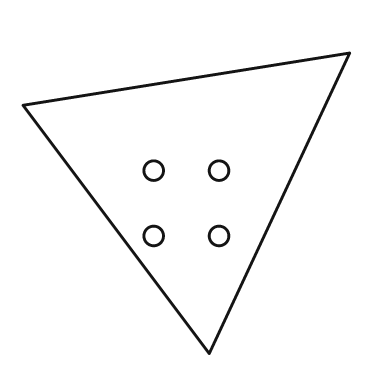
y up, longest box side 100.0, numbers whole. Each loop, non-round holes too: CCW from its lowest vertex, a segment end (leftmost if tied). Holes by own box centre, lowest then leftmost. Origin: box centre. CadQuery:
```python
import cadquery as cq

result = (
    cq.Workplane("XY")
    .moveTo(7.0, -46.0)
    .lineTo(50.0, 46.0)
    .lineTo(-50.0, 30.0)
    .close()
    .moveTo(-10.0, -10.0)
    .circle(3.0)
    .moveTo(10.0, -10.0)
    .circle(3.0)
    .moveTo(-10.0, 10.0)
    .circle(3.0)
    .moveTo(10.0, 10.0)
    .circle(3.0)
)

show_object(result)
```